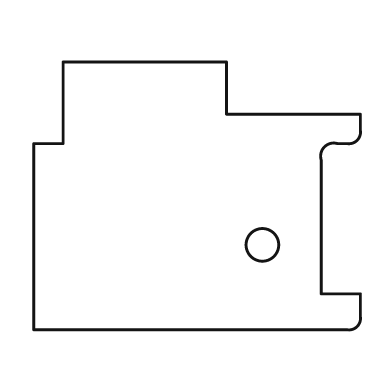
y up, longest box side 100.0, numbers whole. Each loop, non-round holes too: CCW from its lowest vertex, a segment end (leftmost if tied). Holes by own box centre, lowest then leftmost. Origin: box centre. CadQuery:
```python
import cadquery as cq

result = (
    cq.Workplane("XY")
    .moveTo(-50.0, -41.0)
    .lineTo(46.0, -41.0)
    .threePointArc((49.0, -40.0), (50.0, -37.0))
    .lineTo(50.0, -30.0)
    .lineTo(38.0, -30.0)
    .lineTo(38.0, 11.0)
    .threePointArc((39.0, 15.0), (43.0, 16.0))
    .lineTo(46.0, 16.0)
    .threePointArc((49.0, 17.0), (50.0, 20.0))
    .lineTo(50.0, 25.0)
    .lineTo(9.0, 25.0)
    .lineTo(9.0, 41.0)
    .lineTo(-41.0, 41.0)
    .lineTo(-41.0, 16.0)
    .lineTo(-50.0, 16.0)
    .close()
    .moveTo(20.0, -15.0)
    .circle(5.0)
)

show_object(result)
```